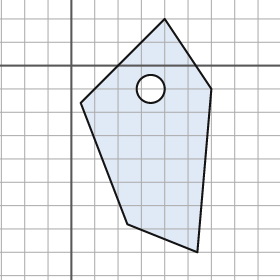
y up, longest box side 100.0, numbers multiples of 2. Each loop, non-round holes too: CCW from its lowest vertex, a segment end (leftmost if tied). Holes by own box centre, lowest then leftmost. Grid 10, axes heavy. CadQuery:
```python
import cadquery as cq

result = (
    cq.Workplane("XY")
    .moveTo(54.0, -80.0)
    .lineTo(60.0, -10.0)
    .lineTo(40.0, 20.0)
    .lineTo(4.0, -16.0)
    .lineTo(24.0, -68.0)
    .close()
    .moveTo(34.0, -10.0)
    .circle(6.0)
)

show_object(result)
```